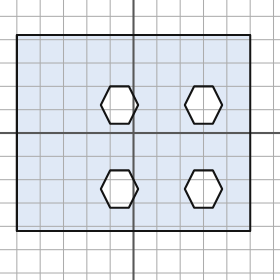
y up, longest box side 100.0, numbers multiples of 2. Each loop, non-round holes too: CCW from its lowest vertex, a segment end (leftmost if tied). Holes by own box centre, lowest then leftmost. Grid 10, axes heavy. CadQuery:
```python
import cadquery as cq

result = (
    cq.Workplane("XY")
    .moveTo(-50.0, -42.0)
    .lineTo(50.0, -42.0)
    .lineTo(50.0, 42.0)
    .lineTo(-50.0, 42.0)
    .close()
    .moveTo(-10.0, -32.0)
    .lineTo(-2.0, -32.0)
    .lineTo(2.0, -24.0)
    .lineTo(-2.0, -16.0)
    .lineTo(-10.0, -16.0)
    .lineTo(-14.0, -24.0)
    .close()
    .moveTo(26.0, -32.0)
    .lineTo(34.0, -32.0)
    .lineTo(38.0, -24.0)
    .lineTo(34.0, -16.0)
    .lineTo(26.0, -16.0)
    .lineTo(22.0, -24.0)
    .close()
    .moveTo(-10.0, 4.0)
    .lineTo(-2.0, 4.0)
    .lineTo(2.0, 12.0)
    .lineTo(-2.0, 20.0)
    .lineTo(-10.0, 20.0)
    .lineTo(-14.0, 12.0)
    .close()
    .moveTo(26.0, 4.0)
    .lineTo(34.0, 4.0)
    .lineTo(38.0, 12.0)
    .lineTo(34.0, 20.0)
    .lineTo(26.0, 20.0)
    .lineTo(22.0, 12.0)
    .close()
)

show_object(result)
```